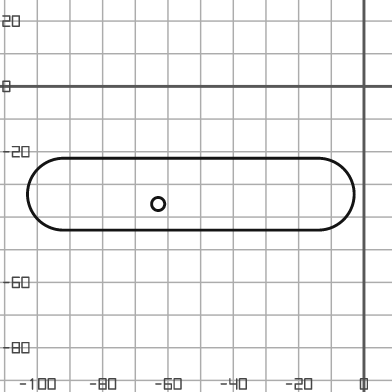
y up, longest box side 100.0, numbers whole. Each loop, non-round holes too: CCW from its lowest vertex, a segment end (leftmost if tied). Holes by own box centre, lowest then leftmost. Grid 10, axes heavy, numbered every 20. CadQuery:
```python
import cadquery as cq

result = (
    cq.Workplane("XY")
    .moveTo(-92.0, -44.0)
    .lineTo(-14.0, -44.0)
    .threePointArc((-3.0, -33.0), (-14.0, -22.0))
    .lineTo(-92.0, -22.0)
    .threePointArc((-103.0, -33.0), (-92.0, -44.0))
    .close()
    .moveTo(-63.0, -36.0)
    .circle(2.0)
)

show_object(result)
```